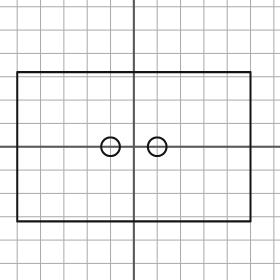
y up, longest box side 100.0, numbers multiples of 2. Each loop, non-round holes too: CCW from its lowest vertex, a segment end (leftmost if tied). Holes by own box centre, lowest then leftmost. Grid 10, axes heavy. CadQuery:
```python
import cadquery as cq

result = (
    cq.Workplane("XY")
    .moveTo(-50.0, -32.0)
    .lineTo(50.0, -32.0)
    .lineTo(50.0, 32.0)
    .lineTo(-50.0, 32.0)
    .close()
    .moveTo(-10.0, 0.0)
    .circle(4.0)
    .moveTo(10.0, 0.0)
    .circle(4.0)
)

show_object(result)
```